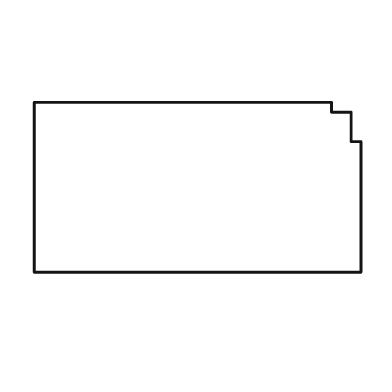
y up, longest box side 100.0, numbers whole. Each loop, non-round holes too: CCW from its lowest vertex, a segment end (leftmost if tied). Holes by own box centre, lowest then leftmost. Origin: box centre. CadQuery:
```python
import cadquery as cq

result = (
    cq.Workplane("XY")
    .moveTo(-50.0, -26.0)
    .lineTo(50.0, -26.0)
    .lineTo(50.0, 14.0)
    .lineTo(47.0, 14.0)
    .lineTo(47.0, 23.0)
    .lineTo(41.0, 23.0)
    .lineTo(41.0, 26.0)
    .lineTo(-50.0, 26.0)
    .close()
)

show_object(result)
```